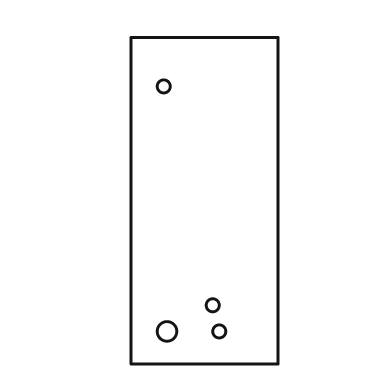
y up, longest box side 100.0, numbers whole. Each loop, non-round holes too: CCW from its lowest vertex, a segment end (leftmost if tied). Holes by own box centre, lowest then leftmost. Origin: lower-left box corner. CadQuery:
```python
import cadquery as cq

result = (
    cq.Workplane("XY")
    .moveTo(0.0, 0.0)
    .lineTo(45.0, 0.0)
    .lineTo(45.0, 100.0)
    .lineTo(0.0, 100.0)
    .close()
    .moveTo(11.0, 10.0)
    .circle(3.0)
    .moveTo(27.0, 10.0)
    .circle(2.0)
    .moveTo(25.0, 18.0)
    .circle(2.0)
    .moveTo(10.0, 85.0)
    .circle(2.0)
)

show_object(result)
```